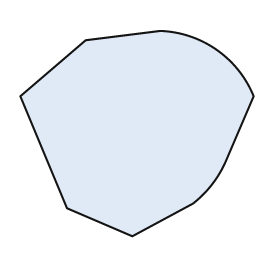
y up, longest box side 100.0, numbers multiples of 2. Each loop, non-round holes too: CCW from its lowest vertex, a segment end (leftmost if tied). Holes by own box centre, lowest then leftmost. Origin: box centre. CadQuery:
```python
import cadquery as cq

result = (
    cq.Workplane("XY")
    .moveTo(-2.0, -44.0)
    .lineTo(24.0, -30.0)
    .threePointArc((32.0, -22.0), (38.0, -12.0))
    .lineTo(50.0, 16.0)
    .threePointArc((34.0, 36.0), (10.0, 44.0))
    .lineTo(-22.0, 40.0)
    .lineTo(-50.0, 16.0)
    .lineTo(-30.0, -32.0)
    .close()
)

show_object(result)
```